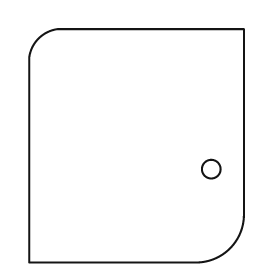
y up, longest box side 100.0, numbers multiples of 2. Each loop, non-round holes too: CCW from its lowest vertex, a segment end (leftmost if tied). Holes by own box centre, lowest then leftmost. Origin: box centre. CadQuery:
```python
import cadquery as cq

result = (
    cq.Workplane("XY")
    .moveTo(-46.0, -50.0)
    .lineTo(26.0, -50.0)
    .threePointArc((40.0, -44.0), (46.0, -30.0))
    .lineTo(46.0, 50.0)
    .lineTo(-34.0, 50.0)
    .threePointArc((-42.0, 46.0), (-46.0, 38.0))
    .close()
    .moveTo(32.0, -10.0)
    .circle(4.0)
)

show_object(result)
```